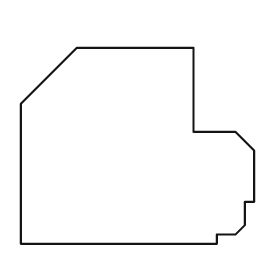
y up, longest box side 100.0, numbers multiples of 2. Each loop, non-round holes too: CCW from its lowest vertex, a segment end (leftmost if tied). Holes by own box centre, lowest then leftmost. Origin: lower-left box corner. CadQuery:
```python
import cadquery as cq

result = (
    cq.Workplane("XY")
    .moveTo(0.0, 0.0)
    .lineTo(84.0, 0.0)
    .lineTo(84.0, 4.0)
    .lineTo(92.0, 4.0)
    .lineTo(96.0, 8.0)
    .lineTo(96.0, 18.0)
    .lineTo(100.0, 18.0)
    .lineTo(100.0, 40.0)
    .lineTo(92.0, 48.0)
    .lineTo(74.0, 48.0)
    .lineTo(74.0, 84.0)
    .lineTo(24.0, 84.0)
    .lineTo(0.0, 60.0)
    .close()
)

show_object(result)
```